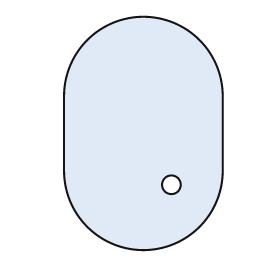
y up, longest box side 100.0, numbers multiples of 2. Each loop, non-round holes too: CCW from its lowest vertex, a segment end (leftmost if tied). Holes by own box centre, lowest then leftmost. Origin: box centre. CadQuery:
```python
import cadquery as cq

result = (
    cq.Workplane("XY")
    .moveTo(-34.0, -16.0)
    .threePointArc((0.0, -50.0), (34.0, -16.0))
    .lineTo(34.0, 16.0)
    .threePointArc((0.0, 50.0), (-34.0, 16.0))
    .close()
    .moveTo(12.0, -22.0)
    .circle(4.0)
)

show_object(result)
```